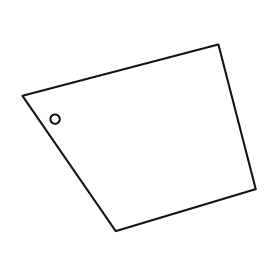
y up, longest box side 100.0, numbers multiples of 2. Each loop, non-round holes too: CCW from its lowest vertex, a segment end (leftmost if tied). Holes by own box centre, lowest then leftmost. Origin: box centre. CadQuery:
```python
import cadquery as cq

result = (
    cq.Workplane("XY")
    .moveTo(-10.0, -40.0)
    .lineTo(50.0, -22.0)
    .lineTo(34.0, 40.0)
    .lineTo(-50.0, 18.0)
    .close()
    .moveTo(-36.0, 8.0)
    .circle(2.0)
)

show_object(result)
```